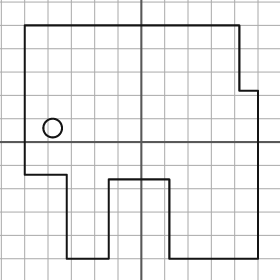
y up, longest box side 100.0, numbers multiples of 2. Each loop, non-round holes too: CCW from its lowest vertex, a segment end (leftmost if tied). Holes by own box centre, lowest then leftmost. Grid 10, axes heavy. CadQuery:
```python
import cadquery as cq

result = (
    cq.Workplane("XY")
    .moveTo(-32.0, -50.0)
    .lineTo(-14.0, -50.0)
    .lineTo(-14.0, -16.0)
    .lineTo(12.0, -16.0)
    .lineTo(12.0, -50.0)
    .lineTo(50.0, -50.0)
    .lineTo(50.0, 22.0)
    .lineTo(42.0, 22.0)
    .lineTo(42.0, 50.0)
    .lineTo(-50.0, 50.0)
    .lineTo(-50.0, -14.0)
    .lineTo(-32.0, -14.0)
    .close()
    .moveTo(-38.0, 6.0)
    .circle(4.0)
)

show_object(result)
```